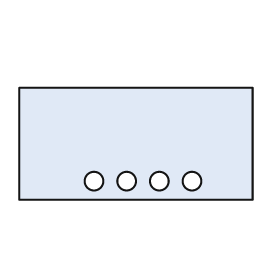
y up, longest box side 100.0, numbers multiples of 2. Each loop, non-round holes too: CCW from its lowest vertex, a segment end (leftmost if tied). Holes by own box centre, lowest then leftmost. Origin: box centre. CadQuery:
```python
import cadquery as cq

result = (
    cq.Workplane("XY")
    .moveTo(-50.0, -24.0)
    .lineTo(50.0, -24.0)
    .lineTo(50.0, 24.0)
    .lineTo(-50.0, 24.0)
    .close()
    .moveTo(-18.0, -16.0)
    .circle(4.0)
    .moveTo(-4.0, -16.0)
    .circle(4.0)
    .moveTo(10.0, -16.0)
    .circle(4.0)
    .moveTo(24.0, -16.0)
    .circle(4.0)
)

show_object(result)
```